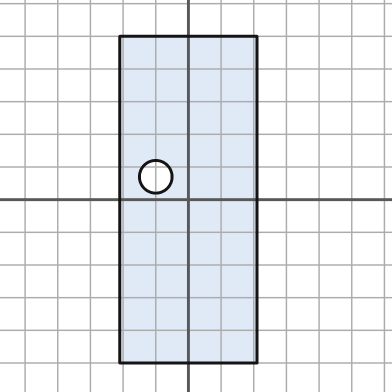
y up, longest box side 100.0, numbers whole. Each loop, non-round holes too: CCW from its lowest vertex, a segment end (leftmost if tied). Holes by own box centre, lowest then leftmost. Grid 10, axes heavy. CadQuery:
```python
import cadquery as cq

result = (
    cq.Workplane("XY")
    .moveTo(-21.0, -50.0)
    .lineTo(21.0, -50.0)
    .lineTo(21.0, 50.0)
    .lineTo(-21.0, 50.0)
    .close()
    .moveTo(-10.0, 7.0)
    .circle(5.0)
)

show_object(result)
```